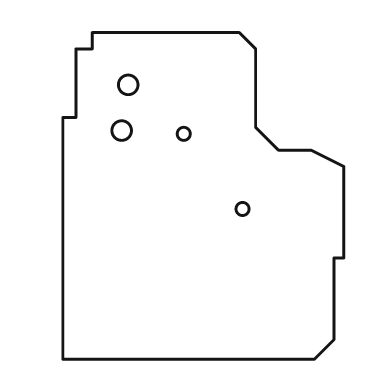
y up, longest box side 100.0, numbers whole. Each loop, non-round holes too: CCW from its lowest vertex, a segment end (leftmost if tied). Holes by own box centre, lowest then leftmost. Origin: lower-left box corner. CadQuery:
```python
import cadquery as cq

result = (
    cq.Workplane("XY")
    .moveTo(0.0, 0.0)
    .lineTo(77.0, 0.0)
    .lineTo(83.0, 6.0)
    .lineTo(83.0, 31.0)
    .lineTo(86.0, 31.0)
    .lineTo(86.0, 59.0)
    .lineTo(76.0, 64.0)
    .lineTo(66.0, 64.0)
    .lineTo(59.0, 71.0)
    .lineTo(59.0, 95.0)
    .lineTo(54.0, 100.0)
    .lineTo(9.0, 100.0)
    .lineTo(9.0, 95.0)
    .lineTo(4.0, 95.0)
    .lineTo(4.0, 74.0)
    .lineTo(0.0, 74.0)
    .close()
    .moveTo(55.0, 46.0)
    .circle(2.0)
    .moveTo(37.0, 69.0)
    .circle(2.0)
    .moveTo(18.0, 70.0)
    .circle(3.0)
    .moveTo(20.0, 84.0)
    .circle(3.0)
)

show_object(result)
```